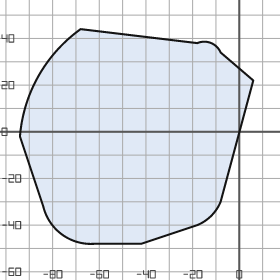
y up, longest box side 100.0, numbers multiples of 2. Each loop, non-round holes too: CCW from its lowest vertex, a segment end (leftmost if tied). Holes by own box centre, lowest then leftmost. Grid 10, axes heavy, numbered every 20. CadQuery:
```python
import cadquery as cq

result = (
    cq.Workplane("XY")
    .moveTo(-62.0, -48.0)
    .lineTo(-42.0, -48.0)
    .lineTo(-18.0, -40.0)
    .threePointArc((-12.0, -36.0), (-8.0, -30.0))
    .lineTo(6.0, 22.0)
    .lineTo(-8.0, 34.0)
    .threePointArc((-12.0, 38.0), (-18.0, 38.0))
    .lineTo(-68.0, 44.0)
    .threePointArc((-86.0, 24.0), (-94.0, -2.0))
    .lineTo(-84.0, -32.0)
    .threePointArc((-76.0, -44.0), (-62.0, -48.0))
    .close()
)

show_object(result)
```